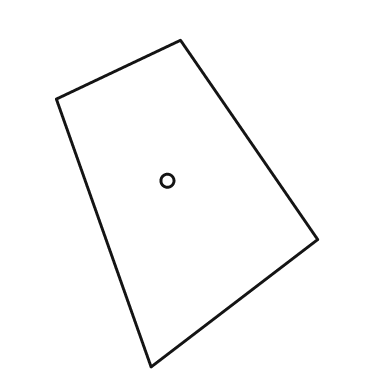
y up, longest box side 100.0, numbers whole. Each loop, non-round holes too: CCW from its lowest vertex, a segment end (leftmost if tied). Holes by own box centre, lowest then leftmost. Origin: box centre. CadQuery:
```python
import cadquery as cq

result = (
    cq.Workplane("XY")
    .moveTo(-11.0, -50.0)
    .lineTo(40.0, -11.0)
    .lineTo(-2.0, 50.0)
    .lineTo(-40.0, 32.0)
    .close()
    .moveTo(-6.0, 7.0)
    .circle(2.0)
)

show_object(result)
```